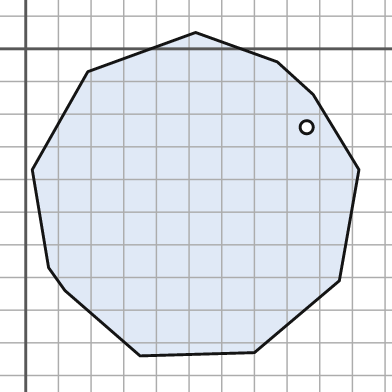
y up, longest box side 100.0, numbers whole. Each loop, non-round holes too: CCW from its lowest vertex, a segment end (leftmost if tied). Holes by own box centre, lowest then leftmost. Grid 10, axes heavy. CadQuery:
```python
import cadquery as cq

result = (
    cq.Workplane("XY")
    .moveTo(35.0, -94.0)
    .lineTo(70.0, -93.0)
    .lineTo(96.0, -71.0)
    .lineTo(102.0, -37.0)
    .lineTo(88.0, -14.0)
    .lineTo(77.0, -4.0)
    .lineTo(52.0, 5.0)
    .lineTo(19.0, -7.0)
    .lineTo(2.0, -37.0)
    .lineTo(7.0, -67.0)
    .lineTo(12.0, -74.0)
    .close()
    .moveTo(86.0, -24.0)
    .circle(2.0)
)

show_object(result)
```